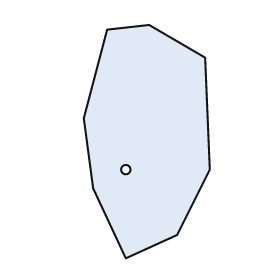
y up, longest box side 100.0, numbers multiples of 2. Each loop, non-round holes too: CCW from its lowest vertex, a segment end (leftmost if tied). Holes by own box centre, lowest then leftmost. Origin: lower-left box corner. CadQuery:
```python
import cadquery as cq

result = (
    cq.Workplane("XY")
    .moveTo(18.0, 0.0)
    .lineTo(40.0, 10.0)
    .lineTo(54.0, 38.0)
    .lineTo(52.0, 86.0)
    .lineTo(28.0, 100.0)
    .lineTo(10.0, 98.0)
    .lineTo(0.0, 60.0)
    .lineTo(4.0, 30.0)
    .close()
    .moveTo(18.0, 38.0)
    .circle(2.0)
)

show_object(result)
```